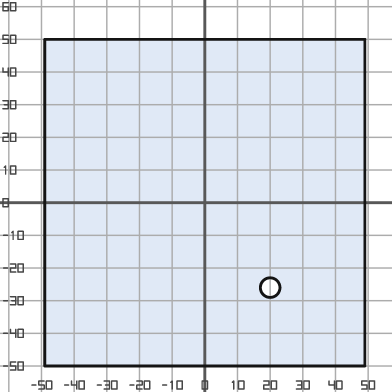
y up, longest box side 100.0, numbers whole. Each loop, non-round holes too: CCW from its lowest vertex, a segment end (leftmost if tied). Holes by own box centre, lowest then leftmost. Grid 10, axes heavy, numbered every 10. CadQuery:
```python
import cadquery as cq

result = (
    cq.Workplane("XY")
    .moveTo(-49.0, -50.0)
    .lineTo(49.0, -50.0)
    .lineTo(49.0, 50.0)
    .lineTo(-49.0, 50.0)
    .close()
    .moveTo(20.0, -26.0)
    .circle(3.0)
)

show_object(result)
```